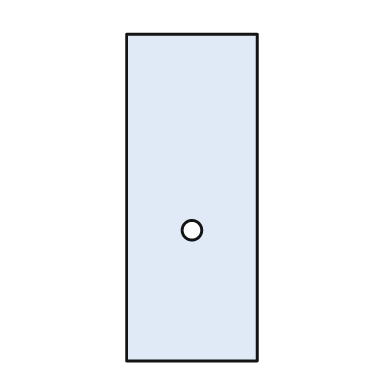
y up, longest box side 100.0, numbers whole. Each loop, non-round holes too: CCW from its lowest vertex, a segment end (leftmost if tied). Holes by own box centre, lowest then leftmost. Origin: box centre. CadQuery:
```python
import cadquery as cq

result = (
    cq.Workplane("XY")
    .moveTo(-20.0, -50.0)
    .lineTo(20.0, -50.0)
    .lineTo(20.0, 50.0)
    .lineTo(-20.0, 50.0)
    .close()
    .moveTo(0.0, -10.0)
    .circle(3.0)
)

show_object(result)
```